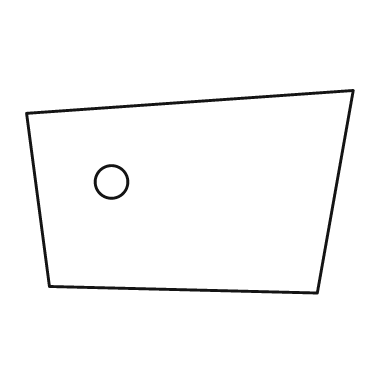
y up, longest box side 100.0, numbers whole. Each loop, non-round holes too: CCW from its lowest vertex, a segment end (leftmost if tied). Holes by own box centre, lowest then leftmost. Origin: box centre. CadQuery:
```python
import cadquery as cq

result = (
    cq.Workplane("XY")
    .moveTo(39.0, -31.0)
    .lineTo(50.0, 31.0)
    .lineTo(-50.0, 24.0)
    .lineTo(-43.0, -29.0)
    .close()
    .moveTo(-24.0, 3.0)
    .circle(5.0)
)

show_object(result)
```